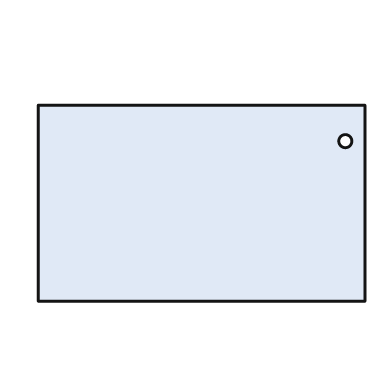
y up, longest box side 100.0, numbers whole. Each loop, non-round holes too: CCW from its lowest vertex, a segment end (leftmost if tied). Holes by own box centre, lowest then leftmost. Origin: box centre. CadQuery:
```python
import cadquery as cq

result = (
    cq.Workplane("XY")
    .moveTo(-50.0, -30.0)
    .lineTo(50.0, -30.0)
    .lineTo(50.0, 30.0)
    .lineTo(-50.0, 30.0)
    .close()
    .moveTo(44.0, 19.0)
    .circle(2.0)
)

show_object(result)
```